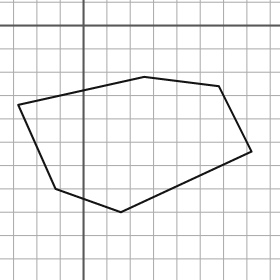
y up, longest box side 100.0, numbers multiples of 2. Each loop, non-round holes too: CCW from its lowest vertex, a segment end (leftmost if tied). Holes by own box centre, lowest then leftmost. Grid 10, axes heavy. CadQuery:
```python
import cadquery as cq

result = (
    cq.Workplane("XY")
    .moveTo(16.0, -80.0)
    .lineTo(72.0, -54.0)
    .lineTo(58.0, -26.0)
    .lineTo(26.0, -22.0)
    .lineTo(-28.0, -34.0)
    .lineTo(-12.0, -70.0)
    .close()
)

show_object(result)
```